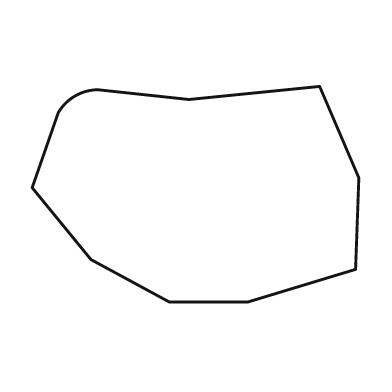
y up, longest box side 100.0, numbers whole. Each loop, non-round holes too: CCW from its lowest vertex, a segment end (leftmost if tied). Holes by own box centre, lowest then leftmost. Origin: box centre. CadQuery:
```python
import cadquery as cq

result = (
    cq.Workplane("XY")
    .moveTo(-8.0, -33.0)
    .lineTo(16.0, -33.0)
    .lineTo(49.0, -23.0)
    .lineTo(50.0, 5.0)
    .lineTo(38.0, 33.0)
    .lineTo(-2.0, 29.0)
    .lineTo(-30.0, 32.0)
    .threePointArc((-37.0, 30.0), (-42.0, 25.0))
    .lineTo(-50.0, 2.0)
    .lineTo(-32.0, -20.0)
    .close()
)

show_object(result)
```